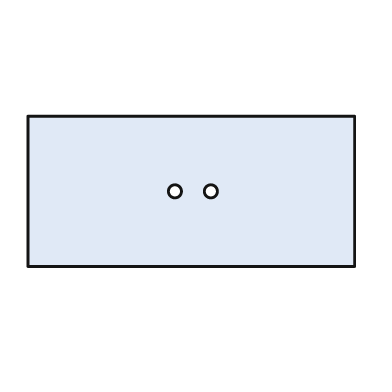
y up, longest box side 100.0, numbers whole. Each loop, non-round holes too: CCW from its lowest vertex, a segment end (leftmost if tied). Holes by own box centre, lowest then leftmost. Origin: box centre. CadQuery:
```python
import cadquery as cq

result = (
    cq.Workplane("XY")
    .moveTo(-50.0, -23.0)
    .lineTo(50.0, -23.0)
    .lineTo(50.0, 23.0)
    .lineTo(-50.0, 23.0)
    .close()
    .moveTo(-5.0, 0.0)
    .circle(2.0)
    .moveTo(6.0, 0.0)
    .circle(2.0)
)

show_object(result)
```